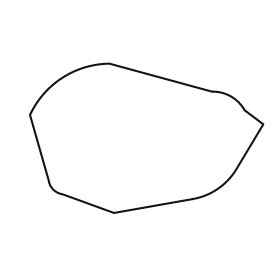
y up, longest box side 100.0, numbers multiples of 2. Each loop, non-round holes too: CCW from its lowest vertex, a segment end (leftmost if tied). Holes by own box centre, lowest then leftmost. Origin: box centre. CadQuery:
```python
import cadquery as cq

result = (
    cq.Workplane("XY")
    .moveTo(-14.0, -32.0)
    .lineTo(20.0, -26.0)
    .threePointArc((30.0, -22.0), (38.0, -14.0))
    .lineTo(50.0, 6.0)
    .lineTo(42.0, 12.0)
    .threePointArc((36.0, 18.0), (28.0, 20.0))
    .lineTo(-16.0, 32.0)
    .threePointArc((-36.0, 26.0), (-50.0, 10.0))
    .lineTo(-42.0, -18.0)
    .threePointArc((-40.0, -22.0), (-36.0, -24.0))
    .close()
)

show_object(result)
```